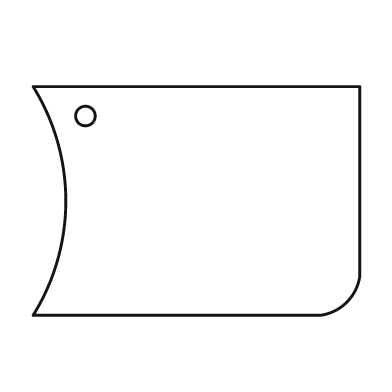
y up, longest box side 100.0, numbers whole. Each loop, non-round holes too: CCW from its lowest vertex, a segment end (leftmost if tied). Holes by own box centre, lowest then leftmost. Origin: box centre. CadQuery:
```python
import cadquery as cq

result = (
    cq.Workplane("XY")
    .moveTo(-50.0, -35.0)
    .lineTo(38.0, -35.0)
    .threePointArc((46.0, -31.0), (50.0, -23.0))
    .lineTo(50.0, 35.0)
    .lineTo(-50.0, 35.0)
    .threePointArc((-40.0, 0.0), (-50.0, -35.0))
    .close()
    .moveTo(-34.0, 26.0)
    .circle(3.0)
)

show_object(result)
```